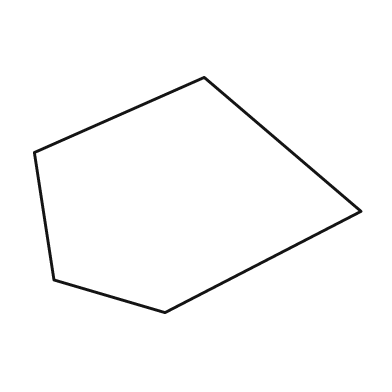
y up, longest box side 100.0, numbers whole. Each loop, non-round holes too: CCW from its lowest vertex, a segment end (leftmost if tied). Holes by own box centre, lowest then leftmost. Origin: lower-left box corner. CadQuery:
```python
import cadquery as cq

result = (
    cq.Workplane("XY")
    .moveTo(40.0, 0.0)
    .lineTo(100.0, 31.0)
    .lineTo(52.0, 72.0)
    .lineTo(0.0, 49.0)
    .lineTo(6.0, 10.0)
    .close()
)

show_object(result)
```